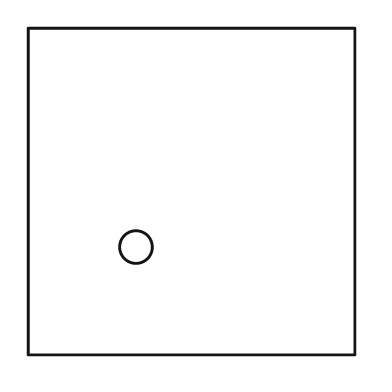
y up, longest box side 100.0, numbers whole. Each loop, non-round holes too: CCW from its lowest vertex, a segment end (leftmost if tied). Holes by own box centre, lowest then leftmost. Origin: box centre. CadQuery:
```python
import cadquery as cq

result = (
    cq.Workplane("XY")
    .moveTo(-50.0, -50.0)
    .lineTo(50.0, -50.0)
    .lineTo(50.0, 50.0)
    .lineTo(-50.0, 50.0)
    .close()
    .moveTo(-17.0, -17.0)
    .circle(5.0)
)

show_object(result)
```